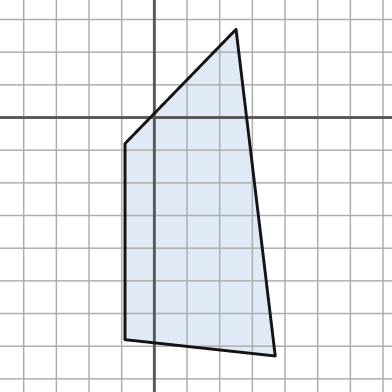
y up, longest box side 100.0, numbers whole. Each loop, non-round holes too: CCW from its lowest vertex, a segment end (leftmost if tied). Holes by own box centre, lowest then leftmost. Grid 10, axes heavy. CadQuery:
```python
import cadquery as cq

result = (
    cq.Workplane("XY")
    .moveTo(37.0, -73.0)
    .lineTo(25.0, 27.0)
    .lineTo(-9.0, -8.0)
    .lineTo(-9.0, -68.0)
    .close()
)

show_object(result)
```